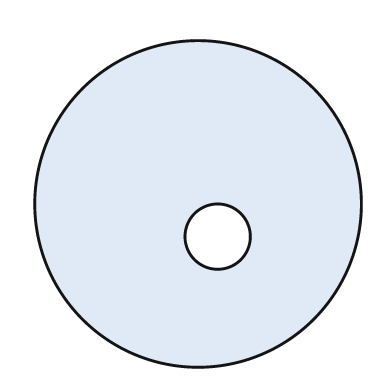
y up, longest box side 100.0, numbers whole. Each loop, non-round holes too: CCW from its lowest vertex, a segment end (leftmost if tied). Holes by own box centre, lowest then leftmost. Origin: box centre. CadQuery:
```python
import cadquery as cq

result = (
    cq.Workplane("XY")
    .moveTo(0.0, 0.0)
    .circle(50.0)
    .moveTo(6.0, -10.0)
    .circle(10.0)
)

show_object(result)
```